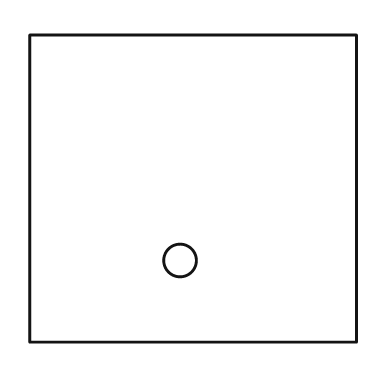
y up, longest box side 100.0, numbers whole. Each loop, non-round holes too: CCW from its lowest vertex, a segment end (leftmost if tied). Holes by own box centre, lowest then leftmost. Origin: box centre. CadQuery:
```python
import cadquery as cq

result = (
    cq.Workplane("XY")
    .moveTo(-50.0, -47.0)
    .lineTo(50.0, -47.0)
    .lineTo(50.0, 47.0)
    .lineTo(-50.0, 47.0)
    .close()
    .moveTo(-4.0, -22.0)
    .circle(5.0)
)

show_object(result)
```